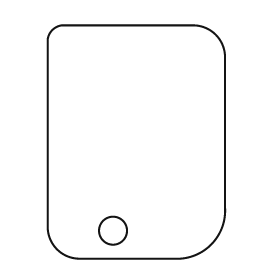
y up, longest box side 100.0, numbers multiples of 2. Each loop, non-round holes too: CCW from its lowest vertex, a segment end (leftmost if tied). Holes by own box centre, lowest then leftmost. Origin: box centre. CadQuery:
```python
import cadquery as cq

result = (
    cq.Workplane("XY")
    .moveTo(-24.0, -50.0)
    .lineTo(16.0, -50.0)
    .threePointArc((32.0, -44.0), (38.0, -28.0))
    .lineTo(38.0, 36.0)
    .threePointArc((34.0, 46.0), (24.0, 50.0))
    .lineTo(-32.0, 50.0)
    .threePointArc((-36.0, 48.0), (-38.0, 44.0))
    .lineTo(-38.0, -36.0)
    .threePointArc((-34.0, -46.0), (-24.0, -50.0))
    .close()
    .moveTo(-10.0, -38.0)
    .circle(6.0)
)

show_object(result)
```